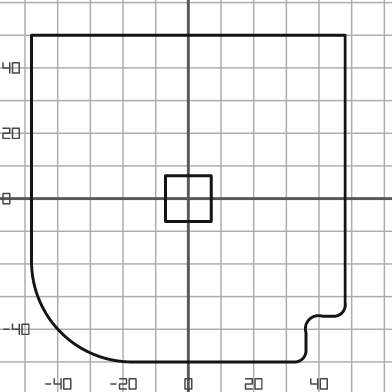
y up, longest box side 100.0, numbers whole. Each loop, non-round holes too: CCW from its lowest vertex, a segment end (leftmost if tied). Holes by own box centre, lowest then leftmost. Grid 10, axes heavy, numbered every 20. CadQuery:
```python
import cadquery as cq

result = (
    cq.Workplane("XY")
    .moveTo(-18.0, -50.0)
    .lineTo(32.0, -50.0)
    .threePointArc((35.0, -49.0), (36.0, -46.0))
    .lineTo(36.0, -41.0)
    .threePointArc((37.0, -37.0), (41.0, -36.0))
    .lineTo(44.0, -36.0)
    .threePointArc((47.0, -35.0), (48.0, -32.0))
    .lineTo(48.0, 50.0)
    .lineTo(-48.0, 50.0)
    .lineTo(-48.0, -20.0)
    .threePointArc((-39.0, -41.0), (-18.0, -50.0))
    .close()
    .moveTo(-7.0, -7.0)
    .lineTo(7.0, -7.0)
    .lineTo(7.0, 7.0)
    .lineTo(-7.0, 7.0)
    .close()
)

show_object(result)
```